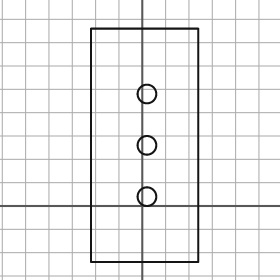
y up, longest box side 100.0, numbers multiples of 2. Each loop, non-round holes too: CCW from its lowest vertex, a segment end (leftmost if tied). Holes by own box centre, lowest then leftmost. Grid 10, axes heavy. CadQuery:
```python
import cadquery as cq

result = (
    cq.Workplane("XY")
    .moveTo(-22.0, -24.0)
    .lineTo(24.0, -24.0)
    .lineTo(24.0, 76.0)
    .lineTo(-22.0, 76.0)
    .close()
    .moveTo(2.0, 4.0)
    .circle(4.0)
    .moveTo(2.0, 26.0)
    .circle(4.0)
    .moveTo(2.0, 48.0)
    .circle(4.0)
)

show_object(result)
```